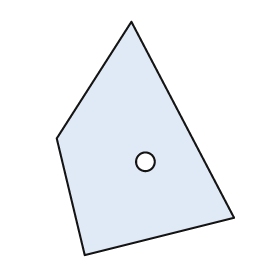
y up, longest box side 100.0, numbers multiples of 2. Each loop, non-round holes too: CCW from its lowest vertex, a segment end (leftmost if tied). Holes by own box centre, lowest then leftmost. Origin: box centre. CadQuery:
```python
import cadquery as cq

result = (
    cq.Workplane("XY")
    .moveTo(-26.0, -50.0)
    .lineTo(38.0, -34.0)
    .lineTo(-6.0, 50.0)
    .lineTo(-38.0, 0.0)
    .close()
    .moveTo(0.0, -10.0)
    .circle(4.0)
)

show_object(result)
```